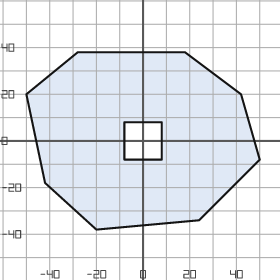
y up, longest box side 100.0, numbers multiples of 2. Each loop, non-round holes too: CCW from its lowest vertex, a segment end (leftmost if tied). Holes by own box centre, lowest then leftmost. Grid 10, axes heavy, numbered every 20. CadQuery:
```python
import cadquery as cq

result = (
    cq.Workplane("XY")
    .moveTo(-20.0, -38.0)
    .lineTo(24.0, -34.0)
    .lineTo(50.0, -8.0)
    .lineTo(42.0, 20.0)
    .lineTo(18.0, 38.0)
    .lineTo(-28.0, 38.0)
    .lineTo(-50.0, 20.0)
    .lineTo(-42.0, -18.0)
    .close()
    .moveTo(-8.0, -8.0)
    .lineTo(8.0, -8.0)
    .lineTo(8.0, 8.0)
    .lineTo(-8.0, 8.0)
    .close()
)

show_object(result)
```